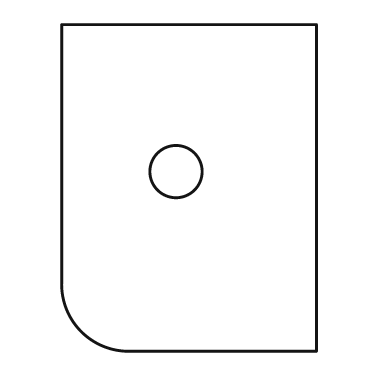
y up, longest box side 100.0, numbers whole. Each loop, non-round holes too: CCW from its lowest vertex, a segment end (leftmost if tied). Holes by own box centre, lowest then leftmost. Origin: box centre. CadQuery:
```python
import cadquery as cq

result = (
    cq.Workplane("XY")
    .moveTo(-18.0, -50.0)
    .lineTo(39.0, -50.0)
    .lineTo(39.0, 50.0)
    .lineTo(-39.0, 50.0)
    .lineTo(-39.0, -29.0)
    .threePointArc((-33.0, -44.0), (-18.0, -50.0))
    .close()
    .moveTo(-4.0, 5.0)
    .circle(8.0)
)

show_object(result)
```